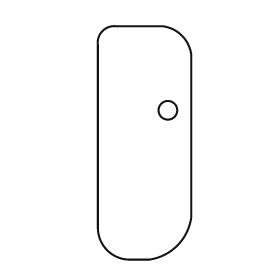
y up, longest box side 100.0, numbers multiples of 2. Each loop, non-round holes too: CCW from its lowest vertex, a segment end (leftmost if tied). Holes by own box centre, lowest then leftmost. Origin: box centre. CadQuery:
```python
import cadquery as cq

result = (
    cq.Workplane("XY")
    .moveTo(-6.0, -50.0)
    .lineTo(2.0, -50.0)
    .threePointArc((14.0, -44.0), (20.0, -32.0))
    .lineTo(20.0, 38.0)
    .threePointArc((16.0, 46.0), (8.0, 50.0))
    .lineTo(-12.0, 50.0)
    .threePointArc((-18.0, 48.0), (-20.0, 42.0))
    .lineTo(-20.0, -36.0)
    .threePointArc((-16.0, -46.0), (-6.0, -50.0))
    .close()
    .moveTo(10.0, 14.0)
    .circle(4.0)
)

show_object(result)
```